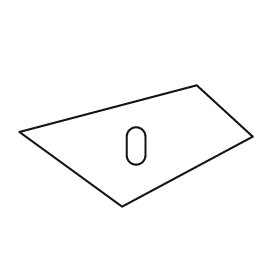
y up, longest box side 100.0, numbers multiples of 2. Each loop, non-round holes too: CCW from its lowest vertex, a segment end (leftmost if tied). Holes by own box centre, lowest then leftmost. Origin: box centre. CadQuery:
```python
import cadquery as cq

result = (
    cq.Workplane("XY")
    .moveTo(-6.0, -26.0)
    .lineTo(50.0, 4.0)
    .lineTo(26.0, 26.0)
    .lineTo(-50.0, 6.0)
    .close()
    .moveTo(-4.0, -4.0)
    .threePointArc((0.0, -8.0), (4.0, -4.0))
    .lineTo(4.0, 4.0)
    .threePointArc((0.0, 8.0), (-4.0, 4.0))
    .close()
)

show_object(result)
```